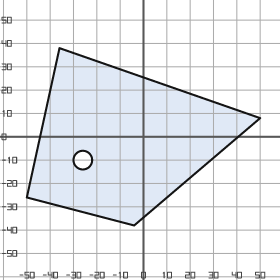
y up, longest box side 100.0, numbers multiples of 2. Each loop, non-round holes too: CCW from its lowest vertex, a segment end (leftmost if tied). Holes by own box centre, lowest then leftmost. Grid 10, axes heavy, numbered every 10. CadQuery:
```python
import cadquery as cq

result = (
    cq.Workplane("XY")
    .moveTo(-4.0, -38.0)
    .lineTo(50.0, 8.0)
    .lineTo(-36.0, 38.0)
    .lineTo(-50.0, -26.0)
    .close()
    .moveTo(-26.0, -10.0)
    .circle(4.0)
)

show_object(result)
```